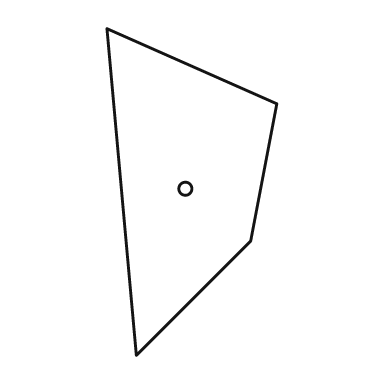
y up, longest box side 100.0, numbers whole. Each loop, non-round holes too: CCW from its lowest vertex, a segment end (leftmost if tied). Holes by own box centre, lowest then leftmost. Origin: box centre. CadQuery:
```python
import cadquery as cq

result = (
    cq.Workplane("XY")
    .moveTo(-17.0, -50.0)
    .lineTo(18.0, -15.0)
    .lineTo(26.0, 27.0)
    .lineTo(-26.0, 50.0)
    .close()
    .moveTo(-2.0, 1.0)
    .circle(2.0)
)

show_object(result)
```